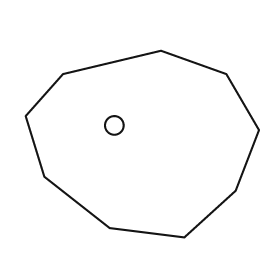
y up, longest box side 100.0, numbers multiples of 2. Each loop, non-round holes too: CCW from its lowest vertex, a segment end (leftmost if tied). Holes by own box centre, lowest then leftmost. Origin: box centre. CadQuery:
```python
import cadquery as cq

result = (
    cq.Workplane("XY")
    .moveTo(18.0, -40.0)
    .lineTo(40.0, -20.0)
    .lineTo(50.0, 6.0)
    .lineTo(36.0, 30.0)
    .lineTo(8.0, 40.0)
    .lineTo(-34.0, 30.0)
    .lineTo(-50.0, 12.0)
    .lineTo(-42.0, -14.0)
    .lineTo(-14.0, -36.0)
    .close()
    .moveTo(-12.0, 8.0)
    .circle(4.0)
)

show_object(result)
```